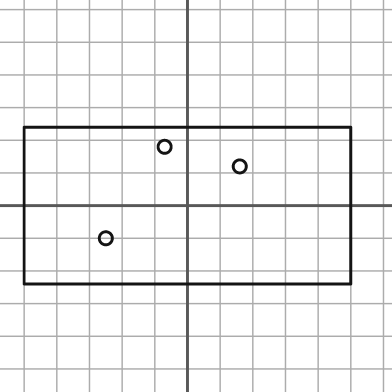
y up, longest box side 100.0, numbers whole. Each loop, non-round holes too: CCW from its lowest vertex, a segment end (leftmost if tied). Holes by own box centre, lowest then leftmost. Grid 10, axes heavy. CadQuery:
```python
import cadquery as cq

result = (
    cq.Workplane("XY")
    .moveTo(-50.0, -24.0)
    .lineTo(50.0, -24.0)
    .lineTo(50.0, 24.0)
    .lineTo(-50.0, 24.0)
    .close()
    .moveTo(-25.0, -10.0)
    .circle(2.0)
    .moveTo(16.0, 12.0)
    .circle(2.0)
    .moveTo(-7.0, 18.0)
    .circle(2.0)
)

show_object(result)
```